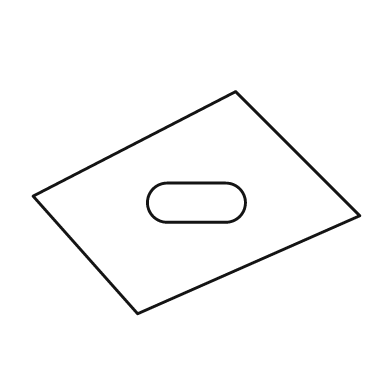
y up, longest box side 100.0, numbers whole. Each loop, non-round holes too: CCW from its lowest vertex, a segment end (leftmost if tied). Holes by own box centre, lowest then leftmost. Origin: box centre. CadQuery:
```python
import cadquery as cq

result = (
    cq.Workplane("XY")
    .moveTo(-18.0, -34.0)
    .lineTo(50.0, -4.0)
    .lineTo(12.0, 34.0)
    .lineTo(-50.0, 2.0)
    .close()
    .moveTo(-9.0, -6.0)
    .lineTo(9.0, -6.0)
    .threePointArc((15.0, 0.0), (9.0, 6.0))
    .lineTo(-9.0, 6.0)
    .threePointArc((-15.0, 0.0), (-9.0, -6.0))
    .close()
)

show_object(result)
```